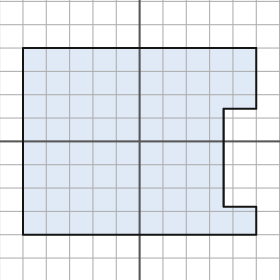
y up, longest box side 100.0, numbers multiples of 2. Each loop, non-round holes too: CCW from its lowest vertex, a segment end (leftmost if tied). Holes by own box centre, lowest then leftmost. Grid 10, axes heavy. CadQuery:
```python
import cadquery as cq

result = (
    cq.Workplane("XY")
    .moveTo(-50.0, -40.0)
    .lineTo(50.0, -40.0)
    .lineTo(50.0, -28.0)
    .lineTo(36.0, -28.0)
    .lineTo(36.0, 14.0)
    .lineTo(50.0, 14.0)
    .lineTo(50.0, 40.0)
    .lineTo(-50.0, 40.0)
    .close()
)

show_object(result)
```